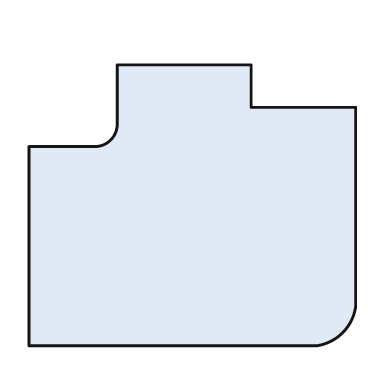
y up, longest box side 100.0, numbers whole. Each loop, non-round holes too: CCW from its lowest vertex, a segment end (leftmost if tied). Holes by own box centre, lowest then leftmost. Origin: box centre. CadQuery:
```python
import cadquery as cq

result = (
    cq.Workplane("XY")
    .moveTo(-50.0, -43.0)
    .lineTo(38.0, -43.0)
    .threePointArc((46.0, -39.0), (50.0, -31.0))
    .lineTo(50.0, 30.0)
    .lineTo(18.0, 30.0)
    .lineTo(18.0, 43.0)
    .lineTo(-23.0, 43.0)
    .lineTo(-23.0, 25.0)
    .threePointArc((-25.0, 20.0), (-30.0, 18.0))
    .lineTo(-50.0, 18.0)
    .close()
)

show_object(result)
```